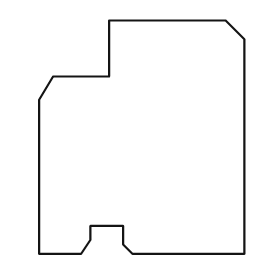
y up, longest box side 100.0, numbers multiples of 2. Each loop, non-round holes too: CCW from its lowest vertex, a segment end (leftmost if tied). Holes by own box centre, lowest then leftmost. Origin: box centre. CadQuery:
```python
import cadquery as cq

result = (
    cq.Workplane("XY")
    .moveTo(-44.0, -50.0)
    .lineTo(-26.0, -50.0)
    .lineTo(-22.0, -44.0)
    .lineTo(-22.0, -38.0)
    .lineTo(-8.0, -38.0)
    .lineTo(-8.0, -46.0)
    .lineTo(-4.0, -50.0)
    .lineTo(44.0, -50.0)
    .lineTo(44.0, 42.0)
    .lineTo(36.0, 50.0)
    .lineTo(-14.0, 50.0)
    .lineTo(-14.0, 26.0)
    .lineTo(-38.0, 26.0)
    .lineTo(-44.0, 16.0)
    .close()
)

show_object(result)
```